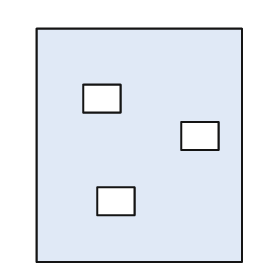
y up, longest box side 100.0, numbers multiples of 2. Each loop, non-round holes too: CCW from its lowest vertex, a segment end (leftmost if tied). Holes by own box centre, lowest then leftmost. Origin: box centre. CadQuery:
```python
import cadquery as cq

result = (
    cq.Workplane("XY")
    .moveTo(-44.0, -50.0)
    .lineTo(44.0, -50.0)
    .lineTo(44.0, 50.0)
    .lineTo(-44.0, 50.0)
    .close()
    .moveTo(-18.0, -30.0)
    .lineTo(-2.0, -30.0)
    .lineTo(-2.0, -18.0)
    .lineTo(-18.0, -18.0)
    .close()
    .moveTo(18.0, -2.0)
    .lineTo(34.0, -2.0)
    .lineTo(34.0, 10.0)
    .lineTo(18.0, 10.0)
    .close()
    .moveTo(-24.0, 14.0)
    .lineTo(-8.0, 14.0)
    .lineTo(-8.0, 26.0)
    .lineTo(-24.0, 26.0)
    .close()
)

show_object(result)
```